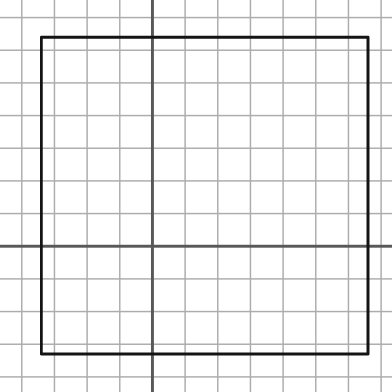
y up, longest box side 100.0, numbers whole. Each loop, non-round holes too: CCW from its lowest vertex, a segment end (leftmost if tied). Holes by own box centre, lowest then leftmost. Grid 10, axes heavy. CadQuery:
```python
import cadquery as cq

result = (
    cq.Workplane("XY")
    .moveTo(-34.0, -33.0)
    .lineTo(66.0, -33.0)
    .lineTo(66.0, 64.0)
    .lineTo(-34.0, 64.0)
    .close()
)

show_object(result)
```